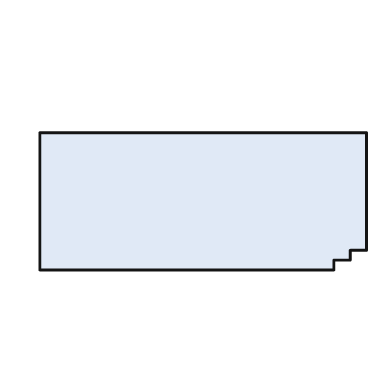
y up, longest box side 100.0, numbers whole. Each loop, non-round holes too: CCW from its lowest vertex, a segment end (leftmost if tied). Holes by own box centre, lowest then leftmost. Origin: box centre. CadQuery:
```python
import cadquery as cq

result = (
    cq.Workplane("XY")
    .moveTo(-50.0, -21.0)
    .lineTo(40.0, -21.0)
    .lineTo(40.0, -18.0)
    .lineTo(45.0, -18.0)
    .lineTo(45.0, -15.0)
    .lineTo(50.0, -15.0)
    .lineTo(50.0, 21.0)
    .lineTo(-50.0, 21.0)
    .close()
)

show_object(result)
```